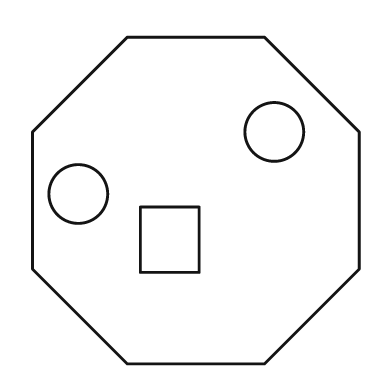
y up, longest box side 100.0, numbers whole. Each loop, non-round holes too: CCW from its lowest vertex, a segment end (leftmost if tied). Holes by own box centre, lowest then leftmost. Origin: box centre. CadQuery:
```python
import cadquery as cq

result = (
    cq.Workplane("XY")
    .moveTo(-21.0, -50.0)
    .lineTo(21.0, -50.0)
    .lineTo(50.0, -21.0)
    .lineTo(50.0, 21.0)
    .lineTo(21.0, 50.0)
    .lineTo(-21.0, 50.0)
    .lineTo(-50.0, 21.0)
    .lineTo(-50.0, -21.0)
    .close()
    .moveTo(-17.0, -22.0)
    .lineTo(1.0, -22.0)
    .lineTo(1.0, -2.0)
    .lineTo(-17.0, -2.0)
    .close()
    .moveTo(-36.0, 2.0)
    .circle(9.0)
    .moveTo(24.0, 21.0)
    .circle(9.0)
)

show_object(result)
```